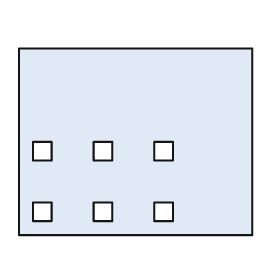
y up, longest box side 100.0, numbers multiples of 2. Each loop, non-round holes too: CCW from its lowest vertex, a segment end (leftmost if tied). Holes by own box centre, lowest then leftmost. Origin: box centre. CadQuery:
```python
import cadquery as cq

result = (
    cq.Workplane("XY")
    .moveTo(-50.0, -40.0)
    .lineTo(50.0, -40.0)
    .lineTo(50.0, 40.0)
    .lineTo(-50.0, 40.0)
    .close()
    .moveTo(-44.0, -34.0)
    .lineTo(-36.0, -34.0)
    .lineTo(-36.0, -26.0)
    .lineTo(-44.0, -26.0)
    .close()
    .moveTo(-18.0, -34.0)
    .lineTo(-10.0, -34.0)
    .lineTo(-10.0, -26.0)
    .lineTo(-18.0, -26.0)
    .close()
    .moveTo(8.0, -34.0)
    .lineTo(16.0, -34.0)
    .lineTo(16.0, -26.0)
    .lineTo(8.0, -26.0)
    .close()
    .moveTo(-44.0, -8.0)
    .lineTo(-36.0, -8.0)
    .lineTo(-36.0, 0.0)
    .lineTo(-44.0, 0.0)
    .close()
    .moveTo(-18.0, -8.0)
    .lineTo(-10.0, -8.0)
    .lineTo(-10.0, 0.0)
    .lineTo(-18.0, 0.0)
    .close()
    .moveTo(8.0, -8.0)
    .lineTo(16.0, -8.0)
    .lineTo(16.0, 0.0)
    .lineTo(8.0, 0.0)
    .close()
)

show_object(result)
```